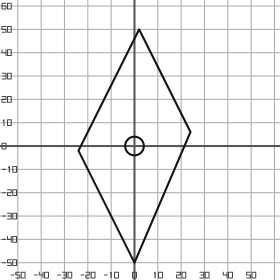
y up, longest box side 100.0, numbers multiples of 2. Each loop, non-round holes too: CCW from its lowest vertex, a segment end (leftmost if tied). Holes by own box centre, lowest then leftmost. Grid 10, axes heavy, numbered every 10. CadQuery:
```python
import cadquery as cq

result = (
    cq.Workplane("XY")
    .moveTo(0.0, -50.0)
    .lineTo(24.0, 6.0)
    .lineTo(2.0, 50.0)
    .lineTo(-24.0, -2.0)
    .close()
    .moveTo(0.0, 0.0)
    .circle(4.0)
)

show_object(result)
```